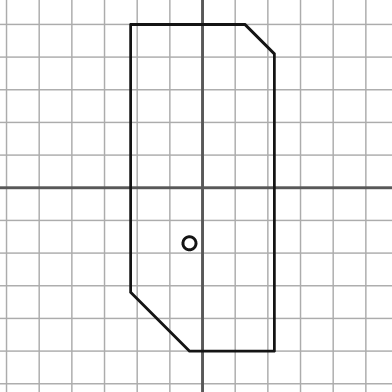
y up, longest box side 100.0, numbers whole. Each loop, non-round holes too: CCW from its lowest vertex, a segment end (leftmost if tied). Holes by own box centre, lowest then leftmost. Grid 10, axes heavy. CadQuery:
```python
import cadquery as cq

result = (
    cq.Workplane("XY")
    .moveTo(-4.0, -50.0)
    .lineTo(22.0, -50.0)
    .lineTo(22.0, 41.0)
    .lineTo(13.0, 50.0)
    .lineTo(-22.0, 50.0)
    .lineTo(-22.0, -32.0)
    .close()
    .moveTo(-4.0, -17.0)
    .circle(2.0)
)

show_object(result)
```